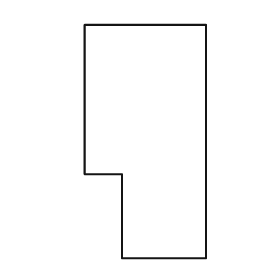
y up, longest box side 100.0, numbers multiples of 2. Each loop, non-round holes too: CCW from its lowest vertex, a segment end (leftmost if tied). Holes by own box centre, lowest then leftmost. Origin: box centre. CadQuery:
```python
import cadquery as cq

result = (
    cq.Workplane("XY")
    .moveTo(-10.0, -50.0)
    .lineTo(26.0, -50.0)
    .lineTo(26.0, 50.0)
    .lineTo(-26.0, 50.0)
    .lineTo(-26.0, -14.0)
    .lineTo(-10.0, -14.0)
    .close()
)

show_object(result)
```